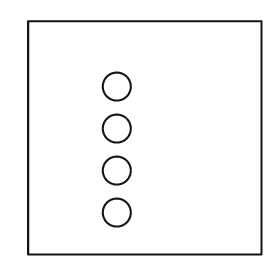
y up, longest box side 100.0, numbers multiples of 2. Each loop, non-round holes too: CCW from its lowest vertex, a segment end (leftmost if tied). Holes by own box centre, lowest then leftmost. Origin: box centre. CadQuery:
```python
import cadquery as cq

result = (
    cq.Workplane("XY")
    .moveTo(-50.0, -50.0)
    .lineTo(50.0, -50.0)
    .lineTo(50.0, 50.0)
    .lineTo(-50.0, 50.0)
    .close()
    .moveTo(-12.0, -32.0)
    .circle(6.0)
    .moveTo(-12.0, -14.0)
    .circle(6.0)
    .moveTo(-12.0, 4.0)
    .circle(6.0)
    .moveTo(-12.0, 22.0)
    .circle(6.0)
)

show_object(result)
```